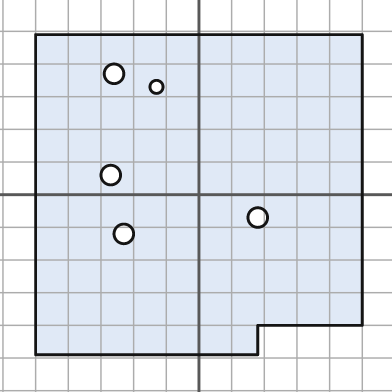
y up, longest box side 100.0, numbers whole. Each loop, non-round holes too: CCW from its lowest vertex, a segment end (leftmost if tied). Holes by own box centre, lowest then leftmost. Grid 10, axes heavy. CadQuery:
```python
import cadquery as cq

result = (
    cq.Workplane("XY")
    .moveTo(-50.0, -49.0)
    .lineTo(18.0, -49.0)
    .lineTo(18.0, -40.0)
    .lineTo(50.0, -40.0)
    .lineTo(50.0, 49.0)
    .lineTo(-50.0, 49.0)
    .close()
    .moveTo(-23.0, -12.0)
    .circle(3.0)
    .moveTo(18.0, -7.0)
    .circle(3.0)
    .moveTo(-27.0, 6.0)
    .circle(3.0)
    .moveTo(-13.0, 33.0)
    .circle(2.0)
    .moveTo(-26.0, 37.0)
    .circle(3.0)
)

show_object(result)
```